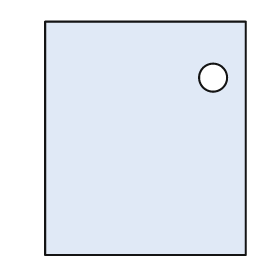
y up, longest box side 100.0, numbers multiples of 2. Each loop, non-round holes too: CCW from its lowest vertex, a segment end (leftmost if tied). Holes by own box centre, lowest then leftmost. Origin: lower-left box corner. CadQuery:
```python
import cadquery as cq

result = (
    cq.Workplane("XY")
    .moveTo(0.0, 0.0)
    .lineTo(86.0, 0.0)
    .lineTo(86.0, 100.0)
    .lineTo(0.0, 100.0)
    .close()
    .moveTo(72.0, 76.0)
    .circle(6.0)
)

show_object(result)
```